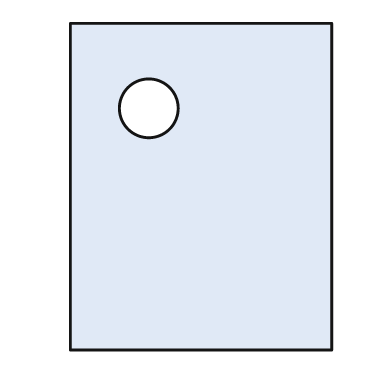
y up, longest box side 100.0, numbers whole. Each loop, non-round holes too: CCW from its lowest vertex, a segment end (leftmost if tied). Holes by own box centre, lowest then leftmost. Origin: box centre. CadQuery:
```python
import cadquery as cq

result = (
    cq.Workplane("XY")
    .moveTo(-40.0, -50.0)
    .lineTo(40.0, -50.0)
    .lineTo(40.0, 50.0)
    .lineTo(-40.0, 50.0)
    .close()
    .moveTo(-16.0, 24.0)
    .circle(9.0)
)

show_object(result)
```